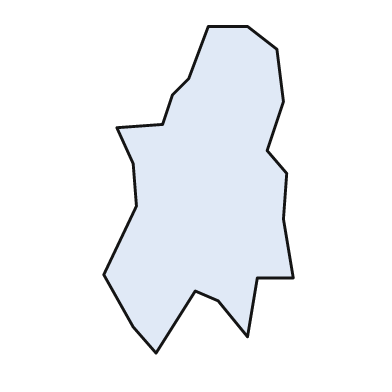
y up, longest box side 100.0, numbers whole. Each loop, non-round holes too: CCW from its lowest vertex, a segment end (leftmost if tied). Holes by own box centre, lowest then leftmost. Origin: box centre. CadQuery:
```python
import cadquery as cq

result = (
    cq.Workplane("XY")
    .moveTo(-13.0, -50.0)
    .lineTo(-1.0, -31.0)
    .lineTo(6.0, -34.0)
    .lineTo(15.0, -45.0)
    .lineTo(18.0, -27.0)
    .lineTo(29.0, -27.0)
    .lineTo(26.0, -9.0)
    .lineTo(27.0, 5.0)
    .lineTo(21.0, 12.0)
    .lineTo(26.0, 27.0)
    .lineTo(24.0, 43.0)
    .lineTo(15.0, 50.0)
    .lineTo(3.0, 50.0)
    .lineTo(-3.0, 34.0)
    .lineTo(-8.0, 29.0)
    .lineTo(-11.0, 20.0)
    .lineTo(-25.0, 19.0)
    .lineTo(-20.0, 8.0)
    .lineTo(-19.0, -5.0)
    .lineTo(-29.0, -26.0)
    .lineTo(-20.0, -42.0)
    .close()
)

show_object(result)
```